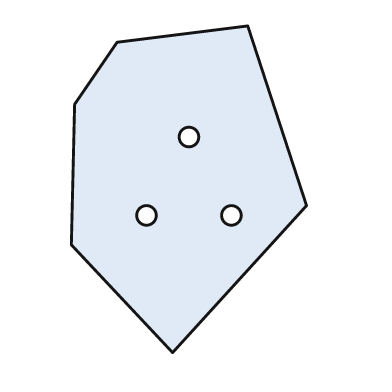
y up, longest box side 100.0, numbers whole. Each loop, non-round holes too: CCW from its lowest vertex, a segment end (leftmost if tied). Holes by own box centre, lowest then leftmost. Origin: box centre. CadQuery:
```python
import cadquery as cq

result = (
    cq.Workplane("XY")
    .moveTo(-5.0, -50.0)
    .lineTo(36.0, -5.0)
    .lineTo(18.0, 50.0)
    .lineTo(-22.0, 45.0)
    .lineTo(-35.0, 26.0)
    .lineTo(-36.0, -17.0)
    .close()
    .moveTo(-13.0, -8.0)
    .circle(3.0)
    .moveTo(13.0, -8.0)
    .circle(3.0)
    .moveTo(0.0, 16.0)
    .circle(3.0)
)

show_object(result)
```